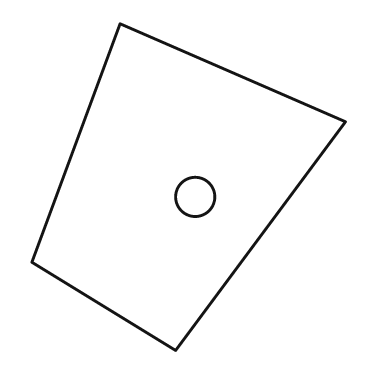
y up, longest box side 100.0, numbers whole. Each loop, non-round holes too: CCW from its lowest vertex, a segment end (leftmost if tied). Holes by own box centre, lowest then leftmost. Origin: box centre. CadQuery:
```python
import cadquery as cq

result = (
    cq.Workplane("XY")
    .moveTo(-4.0, -50.0)
    .lineTo(48.0, 20.0)
    .lineTo(-21.0, 50.0)
    .lineTo(-48.0, -23.0)
    .close()
    .moveTo(2.0, -3.0)
    .circle(6.0)
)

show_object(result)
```